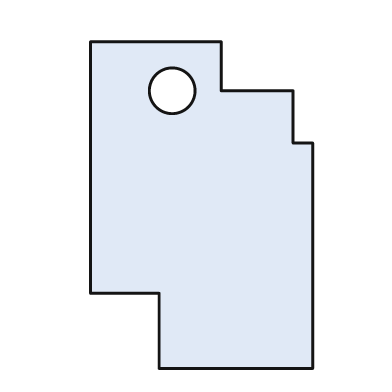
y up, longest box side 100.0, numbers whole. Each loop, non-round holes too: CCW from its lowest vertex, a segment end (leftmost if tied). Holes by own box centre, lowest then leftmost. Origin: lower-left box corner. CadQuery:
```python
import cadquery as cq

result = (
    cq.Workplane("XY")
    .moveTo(21.0, 0.0)
    .lineTo(68.0, 0.0)
    .lineTo(68.0, 69.0)
    .lineTo(62.0, 69.0)
    .lineTo(62.0, 85.0)
    .lineTo(40.0, 85.0)
    .lineTo(40.0, 100.0)
    .lineTo(0.0, 100.0)
    .lineTo(0.0, 23.0)
    .lineTo(21.0, 23.0)
    .close()
    .moveTo(25.0, 85.0)
    .circle(7.0)
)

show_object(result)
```